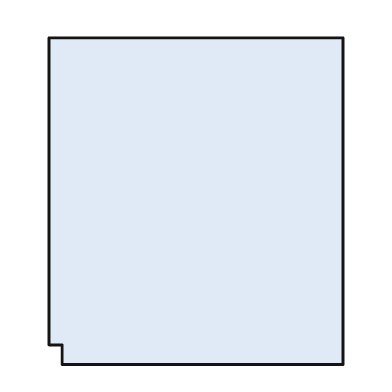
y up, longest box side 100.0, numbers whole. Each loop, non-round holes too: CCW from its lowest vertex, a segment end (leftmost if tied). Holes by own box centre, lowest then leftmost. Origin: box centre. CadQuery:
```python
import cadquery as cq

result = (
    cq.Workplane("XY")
    .moveTo(-41.0, -50.0)
    .lineTo(45.0, -50.0)
    .lineTo(45.0, 50.0)
    .lineTo(-45.0, 50.0)
    .lineTo(-45.0, -44.0)
    .lineTo(-41.0, -44.0)
    .close()
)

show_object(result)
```